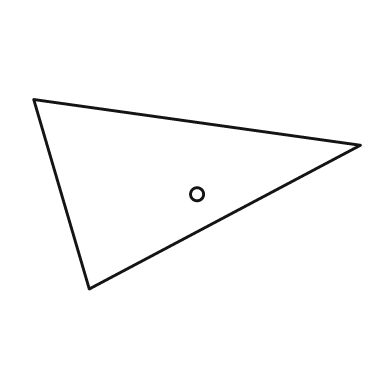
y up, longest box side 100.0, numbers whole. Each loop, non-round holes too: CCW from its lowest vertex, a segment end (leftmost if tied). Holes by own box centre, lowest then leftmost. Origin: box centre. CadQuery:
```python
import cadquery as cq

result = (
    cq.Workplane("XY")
    .moveTo(-33.0, -29.0)
    .lineTo(50.0, 15.0)
    .lineTo(-50.0, 29.0)
    .close()
    .moveTo(0.0, 0.0)
    .circle(2.0)
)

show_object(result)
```